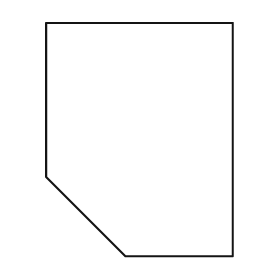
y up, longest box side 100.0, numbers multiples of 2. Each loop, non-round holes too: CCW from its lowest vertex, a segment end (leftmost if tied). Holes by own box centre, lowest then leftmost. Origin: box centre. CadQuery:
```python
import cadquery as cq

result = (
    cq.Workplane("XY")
    .moveTo(-6.0, -50.0)
    .lineTo(40.0, -50.0)
    .lineTo(40.0, 50.0)
    .lineTo(-40.0, 50.0)
    .lineTo(-40.0, -16.0)
    .close()
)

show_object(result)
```